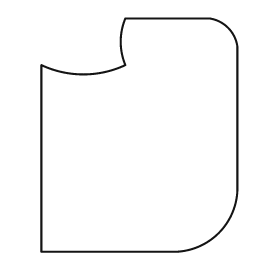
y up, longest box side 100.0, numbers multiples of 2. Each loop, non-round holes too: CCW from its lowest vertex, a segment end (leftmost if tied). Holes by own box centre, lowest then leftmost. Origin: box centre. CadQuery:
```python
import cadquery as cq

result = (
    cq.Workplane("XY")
    .moveTo(-42.0, -50.0)
    .lineTo(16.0, -50.0)
    .threePointArc((34.0, -42.0), (42.0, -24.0))
    .lineTo(42.0, 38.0)
    .threePointArc((38.0, 46.0), (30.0, 50.0))
    .lineTo(-6.0, 50.0)
    .threePointArc((-8.0, 40.0), (-6.0, 30.0))
    .threePointArc((-24.0, 26.0), (-42.0, 30.0))
    .close()
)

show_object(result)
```